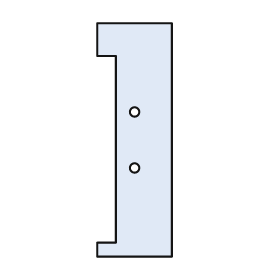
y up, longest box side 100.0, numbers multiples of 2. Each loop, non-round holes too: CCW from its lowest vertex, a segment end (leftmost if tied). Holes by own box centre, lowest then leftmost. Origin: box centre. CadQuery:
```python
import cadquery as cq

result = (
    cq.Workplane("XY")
    .moveTo(-16.0, -50.0)
    .lineTo(16.0, -50.0)
    .lineTo(16.0, 50.0)
    .lineTo(-16.0, 50.0)
    .lineTo(-16.0, 36.0)
    .lineTo(-8.0, 36.0)
    .lineTo(-8.0, -44.0)
    .lineTo(-16.0, -44.0)
    .close()
    .moveTo(0.0, -12.0)
    .circle(2.0)
    .moveTo(0.0, 12.0)
    .circle(2.0)
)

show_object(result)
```